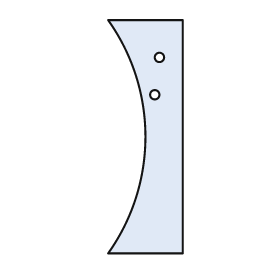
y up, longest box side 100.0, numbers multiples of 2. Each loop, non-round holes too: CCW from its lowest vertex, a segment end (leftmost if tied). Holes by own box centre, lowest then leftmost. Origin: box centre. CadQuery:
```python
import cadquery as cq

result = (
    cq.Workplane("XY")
    .moveTo(-16.0, -50.0)
    .lineTo(16.0, -50.0)
    .lineTo(16.0, 50.0)
    .lineTo(-16.0, 50.0)
    .threePointArc((0.0, 0.0), (-16.0, -50.0))
    .close()
    .moveTo(4.0, 18.0)
    .circle(2.0)
    .moveTo(6.0, 34.0)
    .circle(2.0)
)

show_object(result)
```